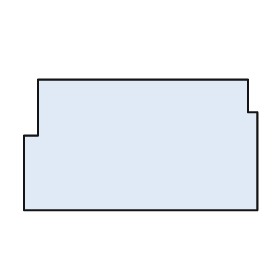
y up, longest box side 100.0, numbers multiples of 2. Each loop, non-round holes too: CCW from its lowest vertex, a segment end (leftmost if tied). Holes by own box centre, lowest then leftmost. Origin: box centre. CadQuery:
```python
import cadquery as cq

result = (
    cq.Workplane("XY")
    .moveTo(-50.0, -28.0)
    .lineTo(50.0, -28.0)
    .lineTo(50.0, 14.0)
    .lineTo(46.0, 14.0)
    .lineTo(46.0, 28.0)
    .lineTo(-44.0, 28.0)
    .lineTo(-44.0, 4.0)
    .lineTo(-50.0, 4.0)
    .close()
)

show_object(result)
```